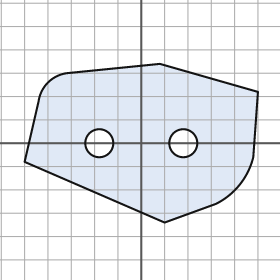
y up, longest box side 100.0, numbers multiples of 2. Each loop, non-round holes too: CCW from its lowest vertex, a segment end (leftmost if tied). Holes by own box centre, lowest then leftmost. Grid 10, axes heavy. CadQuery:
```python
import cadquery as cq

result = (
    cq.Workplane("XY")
    .moveTo(10.0, -34.0)
    .lineTo(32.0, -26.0)
    .threePointArc((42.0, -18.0), (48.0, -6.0))
    .lineTo(50.0, 22.0)
    .lineTo(8.0, 34.0)
    .lineTo(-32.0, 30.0)
    .threePointArc((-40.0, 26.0), (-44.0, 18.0))
    .lineTo(-50.0, -8.0)
    .close()
    .moveTo(-18.0, 0.0)
    .circle(6.0)
    .moveTo(18.0, 0.0)
    .circle(6.0)
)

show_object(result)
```